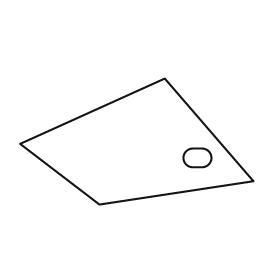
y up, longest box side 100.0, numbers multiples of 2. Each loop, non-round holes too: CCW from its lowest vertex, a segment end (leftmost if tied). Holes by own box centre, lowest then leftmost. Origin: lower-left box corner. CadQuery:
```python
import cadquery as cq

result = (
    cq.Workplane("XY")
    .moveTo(34.0, 0.0)
    .lineTo(100.0, 10.0)
    .lineTo(62.0, 54.0)
    .lineTo(0.0, 26.0)
    .close()
    .moveTo(74.0, 16.0)
    .lineTo(78.0, 16.0)
    .threePointArc((82.0, 20.0), (78.0, 24.0))
    .lineTo(74.0, 24.0)
    .threePointArc((70.0, 20.0), (74.0, 16.0))
    .close()
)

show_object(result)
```